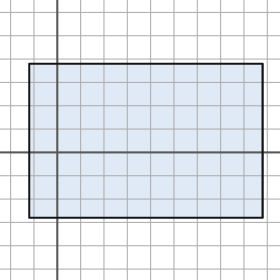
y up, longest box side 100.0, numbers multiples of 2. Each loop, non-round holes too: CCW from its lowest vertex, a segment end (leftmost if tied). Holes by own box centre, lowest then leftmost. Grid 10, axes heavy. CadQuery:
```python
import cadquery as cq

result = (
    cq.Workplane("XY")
    .moveTo(-12.0, -28.0)
    .lineTo(88.0, -28.0)
    .lineTo(88.0, 38.0)
    .lineTo(-12.0, 38.0)
    .close()
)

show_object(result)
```